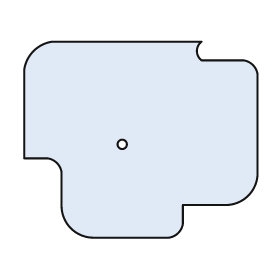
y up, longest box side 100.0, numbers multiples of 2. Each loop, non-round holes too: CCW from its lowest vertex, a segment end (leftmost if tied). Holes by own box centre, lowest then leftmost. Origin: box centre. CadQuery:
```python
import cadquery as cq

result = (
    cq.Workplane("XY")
    .moveTo(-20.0, -42.0)
    .lineTo(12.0, -42.0)
    .threePointArc((16.0, -40.0), (18.0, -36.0))
    .lineTo(18.0, -28.0)
    .lineTo(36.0, -28.0)
    .threePointArc((46.0, -24.0), (50.0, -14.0))
    .lineTo(50.0, 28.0)
    .threePointArc((48.0, 32.0), (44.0, 34.0))
    .lineTo(26.0, 34.0)
    .threePointArc((24.0, 38.0), (26.0, 42.0))
    .lineTo(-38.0, 42.0)
    .threePointArc((-46.0, 38.0), (-50.0, 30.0))
    .lineTo(-50.0, -8.0)
    .lineTo(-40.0, -8.0)
    .threePointArc((-36.0, -10.0), (-34.0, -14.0))
    .lineTo(-34.0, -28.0)
    .threePointArc((-30.0, -38.0), (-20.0, -42.0))
    .close()
    .moveTo(-8.0, -2.0)
    .circle(2.0)
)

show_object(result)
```